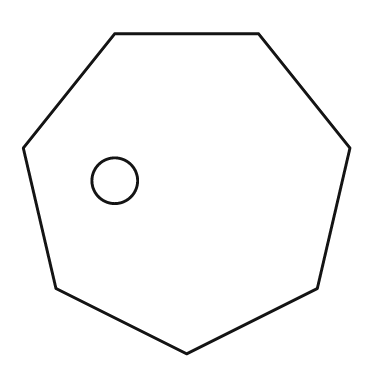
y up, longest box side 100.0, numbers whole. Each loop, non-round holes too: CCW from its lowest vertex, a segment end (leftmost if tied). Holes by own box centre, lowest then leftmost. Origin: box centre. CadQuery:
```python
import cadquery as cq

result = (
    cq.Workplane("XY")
    .moveTo(0.0, -49.0)
    .lineTo(40.0, -29.0)
    .lineTo(50.0, 14.0)
    .lineTo(22.0, 49.0)
    .lineTo(-22.0, 49.0)
    .lineTo(-50.0, 14.0)
    .lineTo(-40.0, -29.0)
    .close()
    .moveTo(-22.0, 4.0)
    .circle(7.0)
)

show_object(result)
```